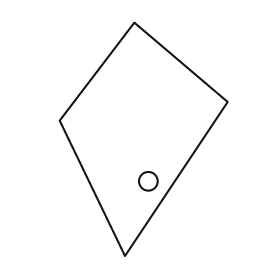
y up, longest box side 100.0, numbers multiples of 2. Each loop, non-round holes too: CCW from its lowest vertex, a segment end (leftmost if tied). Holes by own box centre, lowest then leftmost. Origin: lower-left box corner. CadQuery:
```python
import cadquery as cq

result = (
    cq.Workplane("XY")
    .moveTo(28.0, 0.0)
    .lineTo(72.0, 66.0)
    .lineTo(32.0, 100.0)
    .lineTo(0.0, 58.0)
    .close()
    .moveTo(38.0, 32.0)
    .circle(4.0)
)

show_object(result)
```